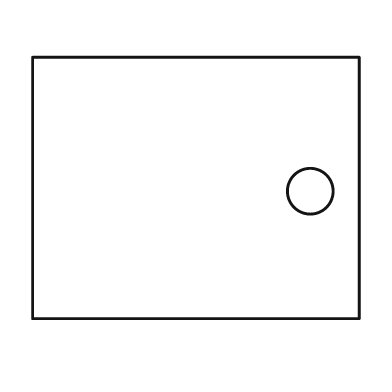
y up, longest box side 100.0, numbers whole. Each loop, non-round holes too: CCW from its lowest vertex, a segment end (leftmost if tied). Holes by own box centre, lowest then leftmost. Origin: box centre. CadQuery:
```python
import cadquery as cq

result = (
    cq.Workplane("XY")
    .moveTo(-50.0, -40.0)
    .lineTo(50.0, -40.0)
    .lineTo(50.0, 40.0)
    .lineTo(-50.0, 40.0)
    .close()
    .moveTo(35.0, -1.0)
    .circle(7.0)
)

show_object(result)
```